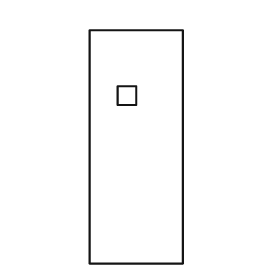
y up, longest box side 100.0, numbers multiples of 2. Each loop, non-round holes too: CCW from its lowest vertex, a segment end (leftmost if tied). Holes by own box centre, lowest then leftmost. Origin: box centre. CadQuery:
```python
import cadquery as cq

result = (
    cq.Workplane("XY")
    .moveTo(-20.0, -50.0)
    .lineTo(20.0, -50.0)
    .lineTo(20.0, 50.0)
    .lineTo(-20.0, 50.0)
    .close()
    .moveTo(-8.0, 18.0)
    .lineTo(0.0, 18.0)
    .lineTo(0.0, 26.0)
    .lineTo(-8.0, 26.0)
    .close()
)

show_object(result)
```